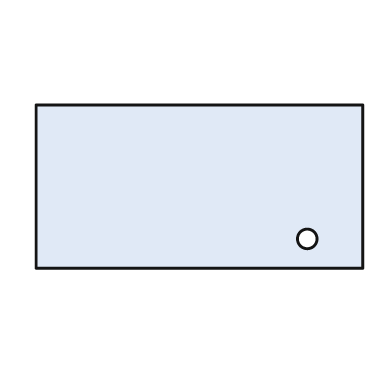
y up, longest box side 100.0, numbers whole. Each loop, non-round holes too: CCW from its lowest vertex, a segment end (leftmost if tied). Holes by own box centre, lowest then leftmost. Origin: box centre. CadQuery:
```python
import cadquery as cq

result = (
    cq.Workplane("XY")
    .moveTo(-50.0, -25.0)
    .lineTo(50.0, -25.0)
    .lineTo(50.0, 25.0)
    .lineTo(-50.0, 25.0)
    .close()
    .moveTo(33.0, -16.0)
    .circle(3.0)
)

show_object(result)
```